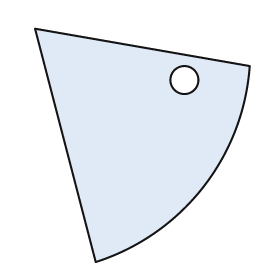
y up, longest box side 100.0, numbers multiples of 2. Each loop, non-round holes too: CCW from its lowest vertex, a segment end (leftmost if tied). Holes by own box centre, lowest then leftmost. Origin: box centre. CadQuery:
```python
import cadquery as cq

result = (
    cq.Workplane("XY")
    .moveTo(-20.0, -50.0)
    .threePointArc((26.0, -18.0), (46.0, 34.0))
    .lineTo(-46.0, 50.0)
    .close()
    .moveTo(18.0, 28.0)
    .circle(6.0)
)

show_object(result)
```